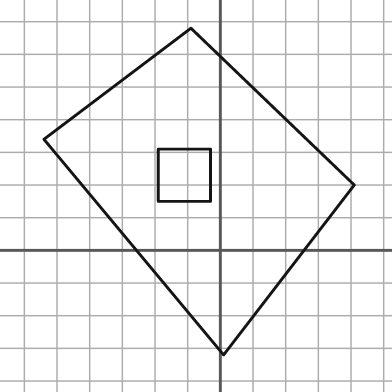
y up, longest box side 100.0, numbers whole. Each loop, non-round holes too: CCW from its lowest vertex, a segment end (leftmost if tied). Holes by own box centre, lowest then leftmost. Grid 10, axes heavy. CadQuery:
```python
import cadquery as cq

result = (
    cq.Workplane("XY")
    .moveTo(1.0, -32.0)
    .lineTo(41.0, 20.0)
    .lineTo(-9.0, 68.0)
    .lineTo(-54.0, 34.0)
    .close()
    .moveTo(-19.0, 15.0)
    .lineTo(-3.0, 15.0)
    .lineTo(-3.0, 31.0)
    .lineTo(-19.0, 31.0)
    .close()
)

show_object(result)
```